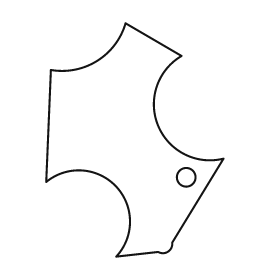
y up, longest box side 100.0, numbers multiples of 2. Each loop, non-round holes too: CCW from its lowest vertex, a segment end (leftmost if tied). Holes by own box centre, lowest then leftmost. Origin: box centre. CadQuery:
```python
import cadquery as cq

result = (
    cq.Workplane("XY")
    .moveTo(-8.0, -50.0)
    .lineTo(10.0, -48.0)
    .threePointArc((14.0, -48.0), (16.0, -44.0))
    .lineTo(38.0, -8.0)
    .threePointArc((10.0, 6.0), (20.0, 36.0))
    .lineTo(-4.0, 50.0)
    .threePointArc((-16.0, 34.0), (-36.0, 30.0))
    .lineTo(-38.0, -18.0)
    .threePointArc((-8.0, -20.0), (-8.0, -50.0))
    .close()
    .moveTo(22.0, -16.0)
    .circle(4.0)
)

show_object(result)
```